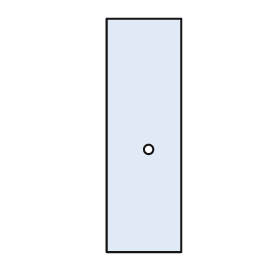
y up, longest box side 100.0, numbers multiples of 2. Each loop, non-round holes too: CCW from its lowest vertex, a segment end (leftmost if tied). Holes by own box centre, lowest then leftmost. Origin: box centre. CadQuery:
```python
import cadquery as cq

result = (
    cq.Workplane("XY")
    .moveTo(-16.0, -50.0)
    .lineTo(16.0, -50.0)
    .lineTo(16.0, 50.0)
    .lineTo(-16.0, 50.0)
    .close()
    .moveTo(2.0, -6.0)
    .circle(2.0)
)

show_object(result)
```